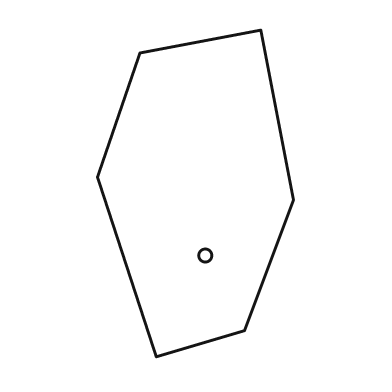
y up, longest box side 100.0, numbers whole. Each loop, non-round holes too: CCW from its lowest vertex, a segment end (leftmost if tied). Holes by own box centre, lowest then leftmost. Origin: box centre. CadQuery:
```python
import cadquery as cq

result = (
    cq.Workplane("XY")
    .moveTo(-12.0, -50.0)
    .lineTo(15.0, -42.0)
    .lineTo(30.0, -2.0)
    .lineTo(20.0, 50.0)
    .lineTo(-17.0, 43.0)
    .lineTo(-30.0, 5.0)
    .close()
    .moveTo(3.0, -19.0)
    .circle(2.0)
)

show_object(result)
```